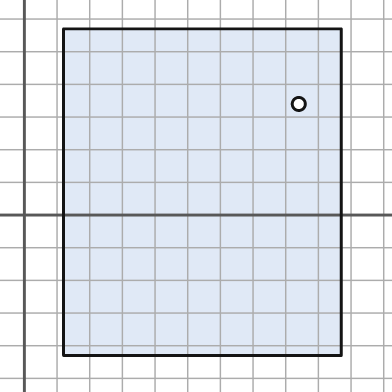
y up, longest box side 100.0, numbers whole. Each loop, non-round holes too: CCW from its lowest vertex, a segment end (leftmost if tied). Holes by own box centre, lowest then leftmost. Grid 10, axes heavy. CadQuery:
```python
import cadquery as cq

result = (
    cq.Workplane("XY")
    .moveTo(12.0, -43.0)
    .lineTo(97.0, -43.0)
    .lineTo(97.0, 57.0)
    .lineTo(12.0, 57.0)
    .close()
    .moveTo(84.0, 34.0)
    .circle(2.0)
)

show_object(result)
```